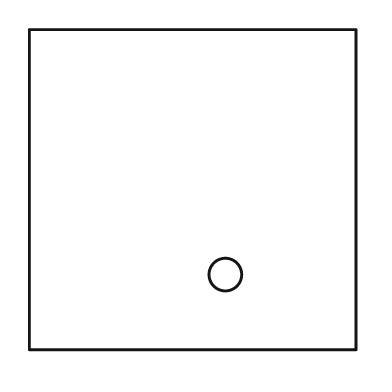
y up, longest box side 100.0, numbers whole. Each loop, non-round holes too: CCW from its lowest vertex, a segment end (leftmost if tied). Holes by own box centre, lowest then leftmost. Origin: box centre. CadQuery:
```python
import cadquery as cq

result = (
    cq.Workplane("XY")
    .moveTo(-50.0, -49.0)
    .lineTo(50.0, -49.0)
    .lineTo(50.0, 49.0)
    .lineTo(-50.0, 49.0)
    .close()
    .moveTo(10.0, -26.0)
    .circle(5.0)
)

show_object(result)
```